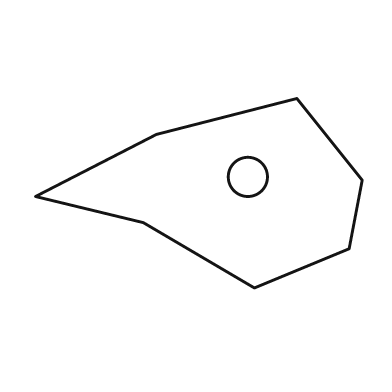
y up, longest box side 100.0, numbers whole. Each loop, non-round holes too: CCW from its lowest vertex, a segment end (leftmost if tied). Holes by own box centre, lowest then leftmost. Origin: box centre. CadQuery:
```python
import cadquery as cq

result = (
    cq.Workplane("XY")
    .moveTo(17.0, -29.0)
    .lineTo(46.0, -17.0)
    .lineTo(50.0, 4.0)
    .lineTo(30.0, 29.0)
    .lineTo(-13.0, 18.0)
    .lineTo(-50.0, -1.0)
    .lineTo(-17.0, -9.0)
    .close()
    .moveTo(15.0, 5.0)
    .circle(6.0)
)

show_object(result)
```